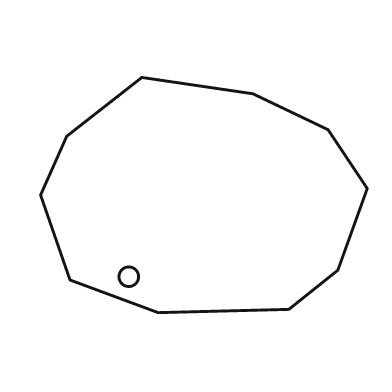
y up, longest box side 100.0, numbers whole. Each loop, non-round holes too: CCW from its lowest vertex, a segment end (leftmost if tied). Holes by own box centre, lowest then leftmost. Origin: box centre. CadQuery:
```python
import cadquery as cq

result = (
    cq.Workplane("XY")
    .moveTo(-14.0, -36.0)
    .lineTo(26.0, -35.0)
    .lineTo(41.0, -23.0)
    .lineTo(50.0, 2.0)
    .lineTo(38.0, 20.0)
    .lineTo(15.0, 31.0)
    .lineTo(-19.0, 36.0)
    .lineTo(-42.0, 18.0)
    .lineTo(-50.0, 0.0)
    .lineTo(-41.0, -26.0)
    .close()
    .moveTo(-23.0, -25.0)
    .circle(3.0)
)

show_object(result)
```